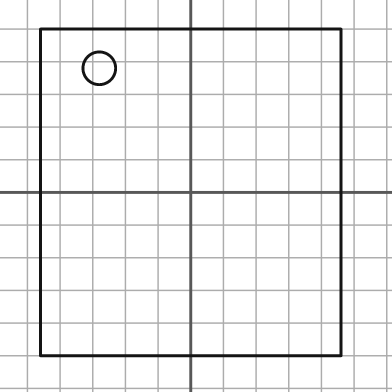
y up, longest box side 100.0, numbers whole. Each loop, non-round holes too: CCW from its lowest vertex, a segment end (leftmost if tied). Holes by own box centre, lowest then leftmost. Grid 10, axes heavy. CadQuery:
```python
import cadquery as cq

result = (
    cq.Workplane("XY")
    .moveTo(-46.0, -50.0)
    .lineTo(46.0, -50.0)
    .lineTo(46.0, 50.0)
    .lineTo(-46.0, 50.0)
    .close()
    .moveTo(-28.0, 38.0)
    .circle(5.0)
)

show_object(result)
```